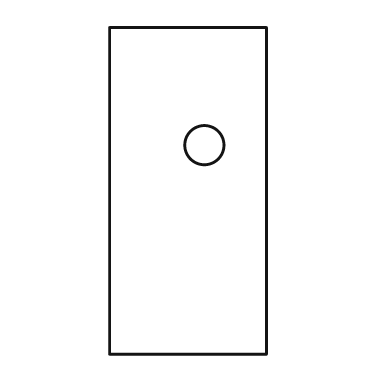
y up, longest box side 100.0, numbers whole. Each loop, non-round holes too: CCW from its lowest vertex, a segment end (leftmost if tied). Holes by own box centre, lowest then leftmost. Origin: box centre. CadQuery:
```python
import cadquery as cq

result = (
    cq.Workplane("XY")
    .moveTo(-24.0, -50.0)
    .lineTo(24.0, -50.0)
    .lineTo(24.0, 50.0)
    .lineTo(-24.0, 50.0)
    .close()
    .moveTo(5.0, 14.0)
    .circle(6.0)
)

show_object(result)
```